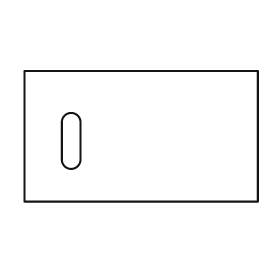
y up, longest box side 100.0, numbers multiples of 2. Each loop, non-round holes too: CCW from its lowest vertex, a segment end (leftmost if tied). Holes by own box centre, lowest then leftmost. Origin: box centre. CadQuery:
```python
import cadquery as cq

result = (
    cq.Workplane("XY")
    .moveTo(-50.0, -28.0)
    .lineTo(50.0, -28.0)
    .lineTo(50.0, 28.0)
    .lineTo(-50.0, 28.0)
    .close()
    .moveTo(-34.0, -10.0)
    .threePointArc((-30.0, -14.0), (-26.0, -10.0))
    .lineTo(-26.0, 6.0)
    .threePointArc((-30.0, 10.0), (-34.0, 6.0))
    .close()
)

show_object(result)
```